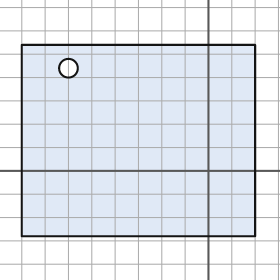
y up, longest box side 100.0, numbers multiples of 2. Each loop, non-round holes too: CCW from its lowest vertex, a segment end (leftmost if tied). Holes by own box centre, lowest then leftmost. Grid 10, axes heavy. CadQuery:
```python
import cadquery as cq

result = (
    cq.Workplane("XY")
    .moveTo(-80.0, -28.0)
    .lineTo(20.0, -28.0)
    .lineTo(20.0, 54.0)
    .lineTo(-80.0, 54.0)
    .close()
    .moveTo(-60.0, 44.0)
    .circle(4.0)
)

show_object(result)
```